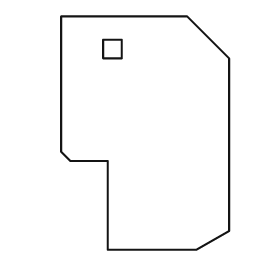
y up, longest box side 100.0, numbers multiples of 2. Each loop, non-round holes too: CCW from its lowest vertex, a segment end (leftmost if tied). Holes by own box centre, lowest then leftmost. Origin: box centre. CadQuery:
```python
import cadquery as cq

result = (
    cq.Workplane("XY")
    .moveTo(-16.0, -50.0)
    .lineTo(22.0, -50.0)
    .lineTo(36.0, -42.0)
    .lineTo(36.0, 32.0)
    .lineTo(18.0, 50.0)
    .lineTo(-36.0, 50.0)
    .lineTo(-36.0, -8.0)
    .lineTo(-32.0, -12.0)
    .lineTo(-16.0, -12.0)
    .close()
    .moveTo(-18.0, 32.0)
    .lineTo(-10.0, 32.0)
    .lineTo(-10.0, 40.0)
    .lineTo(-18.0, 40.0)
    .close()
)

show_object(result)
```